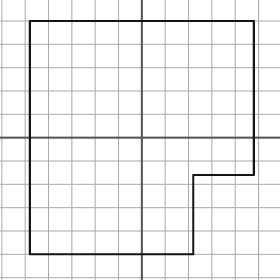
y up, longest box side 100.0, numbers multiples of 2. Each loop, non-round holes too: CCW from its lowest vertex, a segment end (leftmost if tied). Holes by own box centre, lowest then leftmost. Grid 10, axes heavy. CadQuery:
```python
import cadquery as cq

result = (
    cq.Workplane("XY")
    .moveTo(-48.0, -50.0)
    .lineTo(22.0, -50.0)
    .lineTo(22.0, -16.0)
    .lineTo(48.0, -16.0)
    .lineTo(48.0, 50.0)
    .lineTo(-48.0, 50.0)
    .close()
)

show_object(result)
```